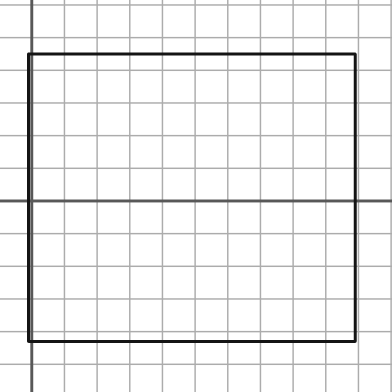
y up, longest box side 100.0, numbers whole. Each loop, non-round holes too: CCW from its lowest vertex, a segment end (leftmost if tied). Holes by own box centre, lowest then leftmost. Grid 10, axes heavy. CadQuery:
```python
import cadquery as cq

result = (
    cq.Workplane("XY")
    .moveTo(-1.0, -43.0)
    .lineTo(99.0, -43.0)
    .lineTo(99.0, 45.0)
    .lineTo(-1.0, 45.0)
    .close()
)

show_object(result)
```